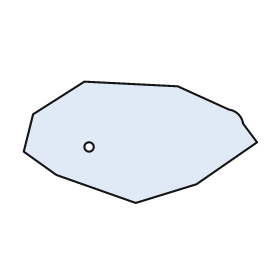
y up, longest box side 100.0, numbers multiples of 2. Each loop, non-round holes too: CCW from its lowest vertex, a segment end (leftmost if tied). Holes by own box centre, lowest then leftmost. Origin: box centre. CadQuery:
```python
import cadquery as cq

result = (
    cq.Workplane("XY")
    .moveTo(-2.0, -26.0)
    .lineTo(24.0, -18.0)
    .lineTo(50.0, 0.0)
    .lineTo(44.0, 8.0)
    .threePointArc((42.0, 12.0), (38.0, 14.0))
    .lineTo(16.0, 24.0)
    .lineTo(-24.0, 26.0)
    .lineTo(-46.0, 12.0)
    .lineTo(-50.0, -4.0)
    .lineTo(-36.0, -14.0)
    .close()
    .moveTo(-22.0, -2.0)
    .circle(2.0)
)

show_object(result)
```